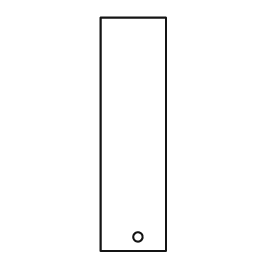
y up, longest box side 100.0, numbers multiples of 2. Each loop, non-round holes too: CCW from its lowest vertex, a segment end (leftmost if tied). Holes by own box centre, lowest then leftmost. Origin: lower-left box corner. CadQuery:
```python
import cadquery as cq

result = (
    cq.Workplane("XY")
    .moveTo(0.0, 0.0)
    .lineTo(28.0, 0.0)
    .lineTo(28.0, 100.0)
    .lineTo(0.0, 100.0)
    .close()
    .moveTo(16.0, 6.0)
    .circle(2.0)
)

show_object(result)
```